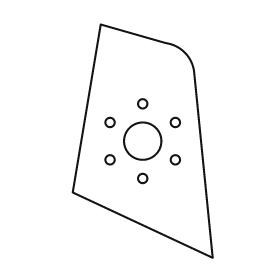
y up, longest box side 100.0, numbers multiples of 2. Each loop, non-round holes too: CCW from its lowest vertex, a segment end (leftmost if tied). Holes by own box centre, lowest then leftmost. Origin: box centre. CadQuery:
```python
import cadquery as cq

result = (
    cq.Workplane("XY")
    .moveTo(30.0, -50.0)
    .lineTo(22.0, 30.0)
    .threePointArc((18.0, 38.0), (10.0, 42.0))
    .lineTo(-18.0, 50.0)
    .lineTo(-30.0, -22.0)
    .close()
    .moveTo(0.0, -16.0)
    .circle(2.0)
    .moveTo(-14.0, -8.0)
    .circle(2.0)
    .moveTo(14.0, -8.0)
    .circle(2.0)
    .moveTo(0.0, 0.0)
    .circle(8.0)
    .moveTo(-14.0, 8.0)
    .circle(2.0)
    .moveTo(14.0, 8.0)
    .circle(2.0)
    .moveTo(0.0, 16.0)
    .circle(2.0)
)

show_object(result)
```